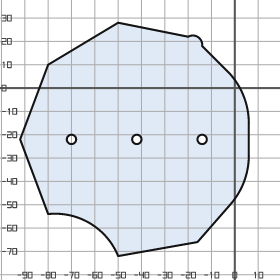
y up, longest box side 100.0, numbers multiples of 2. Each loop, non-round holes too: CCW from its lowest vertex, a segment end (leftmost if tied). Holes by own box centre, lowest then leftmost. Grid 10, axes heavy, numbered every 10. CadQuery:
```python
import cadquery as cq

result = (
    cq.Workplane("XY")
    .moveTo(-50.0, -72.0)
    .lineTo(-16.0, -66.0)
    .lineTo(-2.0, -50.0)
    .threePointArc((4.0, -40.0), (6.0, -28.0))
    .lineTo(6.0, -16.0)
    .threePointArc((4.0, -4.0), (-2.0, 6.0))
    .lineTo(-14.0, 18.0)
    .threePointArc((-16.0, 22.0), (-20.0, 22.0))
    .lineTo(-50.0, 28.0)
    .lineTo(-80.0, 10.0)
    .lineTo(-92.0, -22.0)
    .lineTo(-80.0, -54.0)
    .threePointArc((-62.0, -58.0), (-50.0, -72.0))
    .close()
    .moveTo(-70.0, -22.0)
    .circle(2.0)
    .moveTo(-42.0, -22.0)
    .circle(2.0)
    .moveTo(-14.0, -22.0)
    .circle(2.0)
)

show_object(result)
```